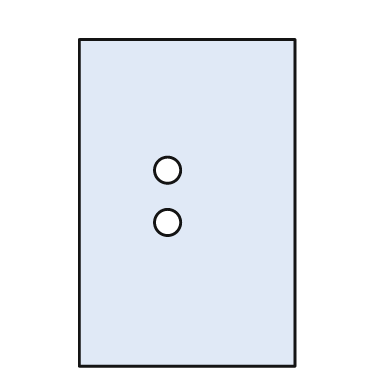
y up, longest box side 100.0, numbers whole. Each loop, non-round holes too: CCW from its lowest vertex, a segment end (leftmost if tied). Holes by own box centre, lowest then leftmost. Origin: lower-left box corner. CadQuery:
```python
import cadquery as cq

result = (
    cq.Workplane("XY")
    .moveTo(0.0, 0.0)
    .lineTo(66.0, 0.0)
    .lineTo(66.0, 100.0)
    .lineTo(0.0, 100.0)
    .close()
    .moveTo(27.0, 44.0)
    .circle(4.0)
    .moveTo(27.0, 60.0)
    .circle(4.0)
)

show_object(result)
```